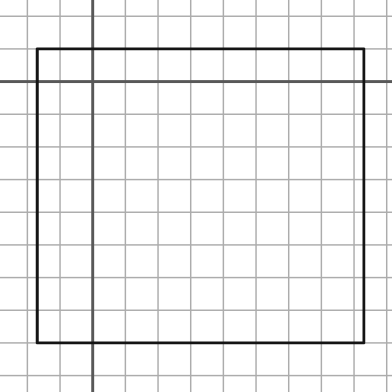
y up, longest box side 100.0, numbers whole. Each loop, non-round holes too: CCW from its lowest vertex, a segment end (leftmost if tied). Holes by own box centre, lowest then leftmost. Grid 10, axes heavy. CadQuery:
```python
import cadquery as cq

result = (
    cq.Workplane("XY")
    .moveTo(-17.0, -80.0)
    .lineTo(83.0, -80.0)
    .lineTo(83.0, 10.0)
    .lineTo(-17.0, 10.0)
    .close()
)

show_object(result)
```